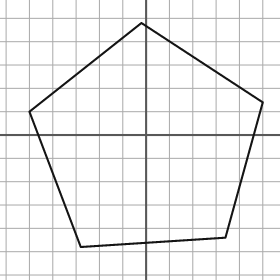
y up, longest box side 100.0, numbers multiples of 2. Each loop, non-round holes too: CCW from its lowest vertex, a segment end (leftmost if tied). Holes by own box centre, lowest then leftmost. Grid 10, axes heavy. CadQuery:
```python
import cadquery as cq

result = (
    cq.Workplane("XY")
    .moveTo(-28.0, -48.0)
    .lineTo(34.0, -44.0)
    .lineTo(50.0, 14.0)
    .lineTo(-2.0, 48.0)
    .lineTo(-50.0, 10.0)
    .close()
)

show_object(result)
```